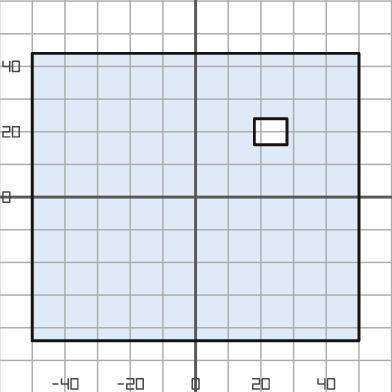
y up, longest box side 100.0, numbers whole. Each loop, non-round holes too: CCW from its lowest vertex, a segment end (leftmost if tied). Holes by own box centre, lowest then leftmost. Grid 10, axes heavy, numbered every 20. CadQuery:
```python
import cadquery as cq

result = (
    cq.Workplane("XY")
    .moveTo(-50.0, -44.0)
    .lineTo(50.0, -44.0)
    .lineTo(50.0, 44.0)
    .lineTo(-50.0, 44.0)
    .close()
    .moveTo(18.0, 16.0)
    .lineTo(28.0, 16.0)
    .lineTo(28.0, 24.0)
    .lineTo(18.0, 24.0)
    .close()
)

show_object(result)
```